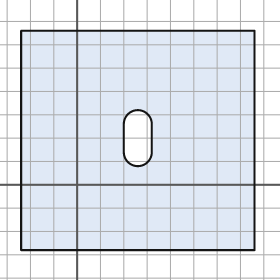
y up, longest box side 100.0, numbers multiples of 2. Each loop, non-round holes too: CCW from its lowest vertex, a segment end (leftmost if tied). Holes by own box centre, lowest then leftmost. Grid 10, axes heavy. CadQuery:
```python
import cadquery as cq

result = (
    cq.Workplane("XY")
    .moveTo(-24.0, -28.0)
    .lineTo(76.0, -28.0)
    .lineTo(76.0, 66.0)
    .lineTo(-24.0, 66.0)
    .close()
    .moveTo(20.0, 14.0)
    .threePointArc((26.0, 8.0), (32.0, 14.0))
    .lineTo(32.0, 26.0)
    .threePointArc((26.0, 32.0), (20.0, 26.0))
    .close()
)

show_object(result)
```